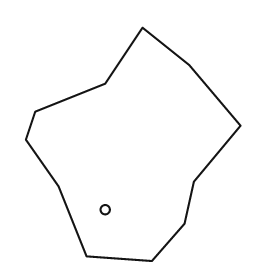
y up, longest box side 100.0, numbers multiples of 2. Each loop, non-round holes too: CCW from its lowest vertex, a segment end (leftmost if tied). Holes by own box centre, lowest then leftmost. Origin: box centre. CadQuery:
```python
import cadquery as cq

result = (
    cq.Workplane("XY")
    .moveTo(8.0, -50.0)
    .lineTo(22.0, -34.0)
    .lineTo(26.0, -16.0)
    .lineTo(46.0, 8.0)
    .lineTo(24.0, 34.0)
    .lineTo(4.0, 50.0)
    .lineTo(-12.0, 26.0)
    .lineTo(-42.0, 14.0)
    .lineTo(-46.0, 2.0)
    .lineTo(-32.0, -18.0)
    .lineTo(-20.0, -48.0)
    .close()
    .moveTo(-12.0, -28.0)
    .circle(2.0)
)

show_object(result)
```